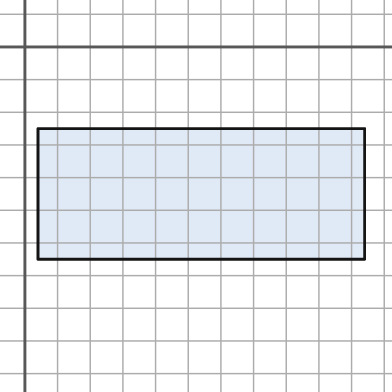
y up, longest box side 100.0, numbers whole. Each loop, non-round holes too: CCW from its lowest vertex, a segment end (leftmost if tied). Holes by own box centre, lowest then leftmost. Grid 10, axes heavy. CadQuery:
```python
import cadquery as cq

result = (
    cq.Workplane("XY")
    .moveTo(4.0, -65.0)
    .lineTo(104.0, -65.0)
    .lineTo(104.0, -25.0)
    .lineTo(4.0, -25.0)
    .close()
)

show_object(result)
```